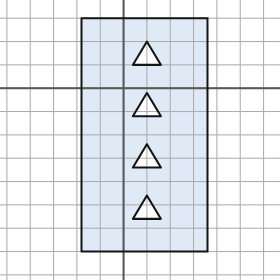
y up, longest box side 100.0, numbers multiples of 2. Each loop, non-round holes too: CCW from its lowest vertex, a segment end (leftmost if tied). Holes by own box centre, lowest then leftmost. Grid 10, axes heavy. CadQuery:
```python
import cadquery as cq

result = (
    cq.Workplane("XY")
    .moveTo(-18.0, -70.0)
    .lineTo(36.0, -70.0)
    .lineTo(36.0, 30.0)
    .lineTo(-18.0, 30.0)
    .close()
    .moveTo(4.0, -56.0)
    .lineTo(16.0, -56.0)
    .lineTo(10.0, -46.0)
    .close()
    .moveTo(4.0, -34.0)
    .lineTo(16.0, -34.0)
    .lineTo(10.0, -24.0)
    .close()
    .moveTo(4.0, -12.0)
    .lineTo(16.0, -12.0)
    .lineTo(10.0, -2.0)
    .close()
    .moveTo(4.0, 10.0)
    .lineTo(16.0, 10.0)
    .lineTo(10.0, 20.0)
    .close()
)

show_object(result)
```